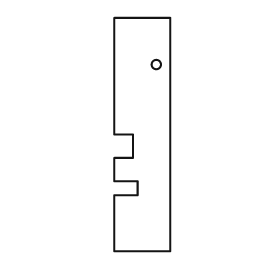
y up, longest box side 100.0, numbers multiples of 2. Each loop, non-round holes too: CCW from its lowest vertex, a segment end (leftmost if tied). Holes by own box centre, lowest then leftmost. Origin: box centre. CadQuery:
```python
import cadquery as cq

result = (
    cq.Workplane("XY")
    .moveTo(-12.0, -50.0)
    .lineTo(12.0, -50.0)
    .lineTo(12.0, 50.0)
    .lineTo(-12.0, 50.0)
    .lineTo(-12.0, 0.0)
    .lineTo(-4.0, 0.0)
    .lineTo(-4.0, -10.0)
    .lineTo(-12.0, -10.0)
    .lineTo(-12.0, -20.0)
    .lineTo(-2.0, -20.0)
    .lineTo(-2.0, -26.0)
    .lineTo(-12.0, -26.0)
    .close()
    .moveTo(6.0, 30.0)
    .circle(2.0)
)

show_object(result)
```